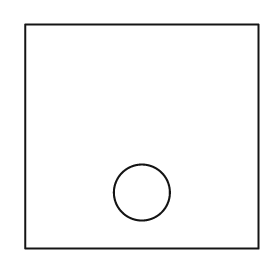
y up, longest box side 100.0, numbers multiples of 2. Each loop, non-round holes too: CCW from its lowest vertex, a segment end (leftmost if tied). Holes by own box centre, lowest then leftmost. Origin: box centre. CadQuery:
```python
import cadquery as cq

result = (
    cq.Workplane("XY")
    .moveTo(-50.0, -48.0)
    .lineTo(50.0, -48.0)
    .lineTo(50.0, 48.0)
    .lineTo(-50.0, 48.0)
    .close()
    .moveTo(0.0, -24.0)
    .circle(12.0)
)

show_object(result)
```